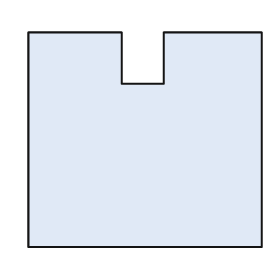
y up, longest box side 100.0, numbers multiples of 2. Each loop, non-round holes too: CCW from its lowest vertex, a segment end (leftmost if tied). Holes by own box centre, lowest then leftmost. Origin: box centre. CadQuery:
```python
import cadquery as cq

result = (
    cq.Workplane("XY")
    .moveTo(-50.0, -46.0)
    .lineTo(50.0, -46.0)
    .lineTo(50.0, 46.0)
    .lineTo(8.0, 46.0)
    .lineTo(8.0, 24.0)
    .lineTo(-10.0, 24.0)
    .lineTo(-10.0, 46.0)
    .lineTo(-50.0, 46.0)
    .close()
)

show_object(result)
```